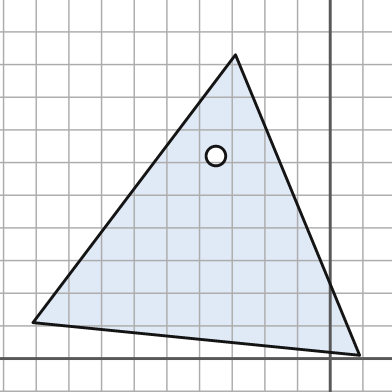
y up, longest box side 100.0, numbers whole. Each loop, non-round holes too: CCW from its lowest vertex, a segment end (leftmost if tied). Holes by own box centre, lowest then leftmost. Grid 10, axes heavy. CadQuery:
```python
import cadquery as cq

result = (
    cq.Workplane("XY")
    .moveTo(9.0, 1.0)
    .lineTo(-29.0, 93.0)
    .lineTo(-91.0, 11.0)
    .close()
    .moveTo(-35.0, 62.0)
    .circle(3.0)
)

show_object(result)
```